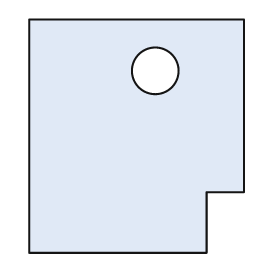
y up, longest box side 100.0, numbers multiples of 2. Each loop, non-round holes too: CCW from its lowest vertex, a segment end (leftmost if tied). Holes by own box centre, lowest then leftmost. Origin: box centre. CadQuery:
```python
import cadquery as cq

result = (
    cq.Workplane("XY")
    .moveTo(-46.0, -50.0)
    .lineTo(30.0, -50.0)
    .lineTo(30.0, -24.0)
    .lineTo(46.0, -24.0)
    .lineTo(46.0, 50.0)
    .lineTo(-46.0, 50.0)
    .close()
    .moveTo(8.0, 28.0)
    .circle(10.0)
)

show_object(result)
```